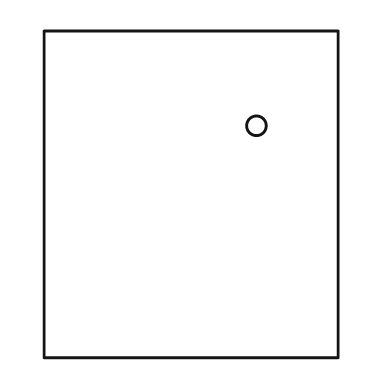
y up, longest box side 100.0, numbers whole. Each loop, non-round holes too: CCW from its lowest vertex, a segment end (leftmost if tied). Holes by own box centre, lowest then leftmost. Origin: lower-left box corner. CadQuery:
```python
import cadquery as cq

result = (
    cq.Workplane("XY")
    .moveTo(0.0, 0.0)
    .lineTo(90.0, 0.0)
    .lineTo(90.0, 100.0)
    .lineTo(0.0, 100.0)
    .close()
    .moveTo(65.0, 71.0)
    .circle(3.0)
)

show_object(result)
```